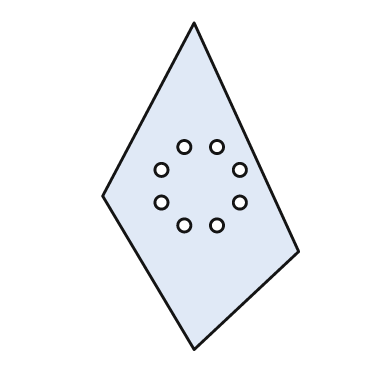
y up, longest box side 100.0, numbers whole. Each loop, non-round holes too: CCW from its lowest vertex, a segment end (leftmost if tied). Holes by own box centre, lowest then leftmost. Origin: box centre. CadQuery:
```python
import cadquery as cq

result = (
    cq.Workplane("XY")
    .moveTo(-2.0, -50.0)
    .lineTo(30.0, -20.0)
    .lineTo(-2.0, 50.0)
    .lineTo(-30.0, -3.0)
    .close()
    .moveTo(-5.0, -12.0)
    .circle(2.0)
    .moveTo(5.0, -12.0)
    .circle(2.0)
    .moveTo(-12.0, -5.0)
    .circle(2.0)
    .moveTo(12.0, -5.0)
    .circle(2.0)
    .moveTo(-12.0, 5.0)
    .circle(2.0)
    .moveTo(12.0, 5.0)
    .circle(2.0)
    .moveTo(-5.0, 12.0)
    .circle(2.0)
    .moveTo(5.0, 12.0)
    .circle(2.0)
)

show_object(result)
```